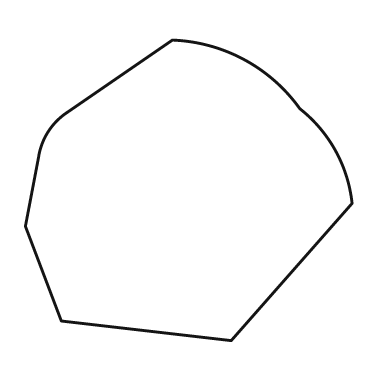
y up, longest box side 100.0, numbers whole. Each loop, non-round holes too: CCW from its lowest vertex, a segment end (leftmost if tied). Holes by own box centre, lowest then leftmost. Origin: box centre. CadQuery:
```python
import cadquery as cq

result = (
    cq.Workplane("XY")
    .moveTo(13.0, -46.0)
    .lineTo(50.0, -4.0)
    .threePointArc((45.0, 12.0), (34.0, 25.0))
    .threePointArc((17.0, 40.0), (-5.0, 46.0))
    .lineTo(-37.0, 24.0)
    .threePointArc((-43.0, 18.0), (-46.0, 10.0))
    .lineTo(-50.0, -11.0)
    .lineTo(-39.0, -40.0)
    .close()
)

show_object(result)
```